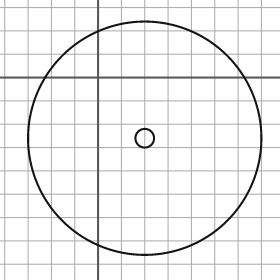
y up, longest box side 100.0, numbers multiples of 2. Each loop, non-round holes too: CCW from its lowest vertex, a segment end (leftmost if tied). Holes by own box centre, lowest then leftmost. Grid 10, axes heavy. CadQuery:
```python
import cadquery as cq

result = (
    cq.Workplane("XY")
    .moveTo(20.0, -26.0)
    .circle(50.0)
    .moveTo(20.0, -26.0)
    .circle(4.0)
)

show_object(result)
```